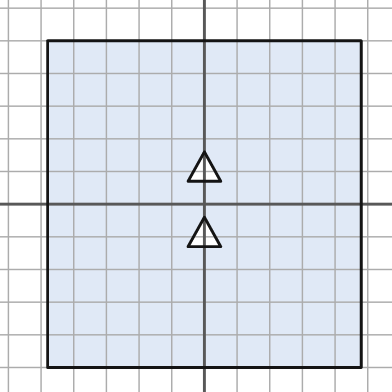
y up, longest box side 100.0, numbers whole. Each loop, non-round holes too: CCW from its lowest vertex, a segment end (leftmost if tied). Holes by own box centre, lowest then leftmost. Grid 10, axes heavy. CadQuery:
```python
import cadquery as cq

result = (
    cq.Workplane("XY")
    .moveTo(-48.0, -50.0)
    .lineTo(48.0, -50.0)
    .lineTo(48.0, 50.0)
    .lineTo(-48.0, 50.0)
    .close()
    .moveTo(-5.0, -13.0)
    .lineTo(5.0, -13.0)
    .lineTo(0.0, -4.0)
    .close()
    .moveTo(-5.0, 7.0)
    .lineTo(5.0, 7.0)
    .lineTo(0.0, 16.0)
    .close()
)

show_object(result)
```